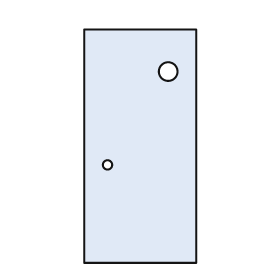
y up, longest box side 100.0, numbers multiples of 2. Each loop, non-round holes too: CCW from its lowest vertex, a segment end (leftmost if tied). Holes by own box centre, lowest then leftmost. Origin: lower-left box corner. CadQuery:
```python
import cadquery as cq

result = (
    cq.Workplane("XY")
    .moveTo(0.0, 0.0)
    .lineTo(48.0, 0.0)
    .lineTo(48.0, 100.0)
    .lineTo(0.0, 100.0)
    .close()
    .moveTo(10.0, 42.0)
    .circle(2.0)
    .moveTo(36.0, 82.0)
    .circle(4.0)
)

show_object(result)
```